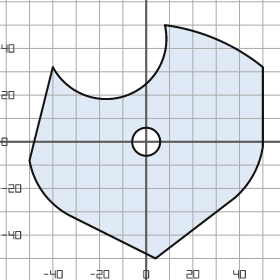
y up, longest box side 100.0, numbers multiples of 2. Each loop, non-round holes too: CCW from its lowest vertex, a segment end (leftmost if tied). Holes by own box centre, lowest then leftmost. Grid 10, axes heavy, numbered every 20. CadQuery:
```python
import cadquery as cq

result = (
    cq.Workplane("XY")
    .moveTo(4.0, -50.0)
    .lineTo(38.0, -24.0)
    .threePointArc((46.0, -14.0), (50.0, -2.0))
    .lineTo(50.0, 32.0)
    .threePointArc((30.0, 44.0), (8.0, 50.0))
    .threePointArc((-8.0, 20.0), (-40.0, 32.0))
    .lineTo(-50.0, -8.0)
    .threePointArc((-44.0, -22.0), (-32.0, -32.0))
    .close()
    .moveTo(0.0, 0.0)
    .circle(6.0)
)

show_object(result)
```